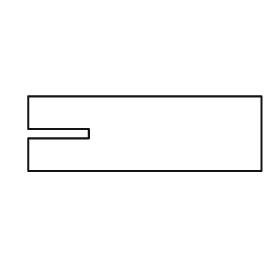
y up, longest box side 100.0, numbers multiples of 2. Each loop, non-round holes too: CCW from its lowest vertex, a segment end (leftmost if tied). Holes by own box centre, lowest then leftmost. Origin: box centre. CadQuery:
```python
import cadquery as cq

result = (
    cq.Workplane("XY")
    .moveTo(-50.0, -16.0)
    .lineTo(50.0, -16.0)
    .lineTo(50.0, 16.0)
    .lineTo(-50.0, 16.0)
    .lineTo(-50.0, 2.0)
    .lineTo(-24.0, 2.0)
    .lineTo(-24.0, -2.0)
    .lineTo(-50.0, -2.0)
    .close()
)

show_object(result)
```